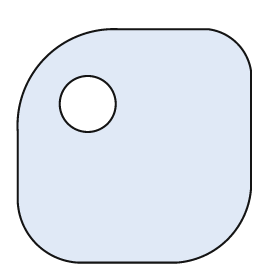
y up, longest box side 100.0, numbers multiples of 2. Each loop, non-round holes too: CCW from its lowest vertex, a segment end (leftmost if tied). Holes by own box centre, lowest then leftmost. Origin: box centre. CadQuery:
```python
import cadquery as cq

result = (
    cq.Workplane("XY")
    .moveTo(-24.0, -50.0)
    .lineTo(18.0, -50.0)
    .threePointArc((40.0, -40.0), (50.0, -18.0))
    .lineTo(50.0, 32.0)
    .threePointArc((44.0, 44.0), (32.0, 50.0))
    .lineTo(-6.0, 50.0)
    .threePointArc((-38.0, 38.0), (-50.0, 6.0))
    .lineTo(-50.0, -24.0)
    .threePointArc((-42.0, -42.0), (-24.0, -50.0))
    .close()
    .moveTo(-20.0, 18.0)
    .circle(12.0)
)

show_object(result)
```